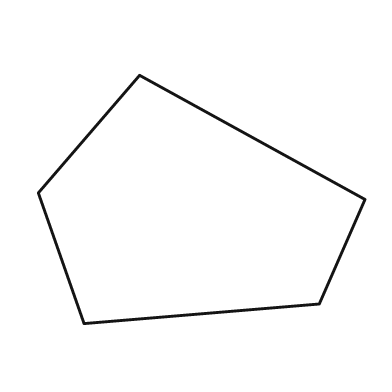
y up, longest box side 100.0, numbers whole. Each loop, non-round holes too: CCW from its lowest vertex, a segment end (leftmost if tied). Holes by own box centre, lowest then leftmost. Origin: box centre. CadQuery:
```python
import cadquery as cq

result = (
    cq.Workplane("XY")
    .moveTo(-36.0, -38.0)
    .lineTo(36.0, -32.0)
    .lineTo(50.0, 0.0)
    .lineTo(-19.0, 38.0)
    .lineTo(-50.0, 2.0)
    .close()
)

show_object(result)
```